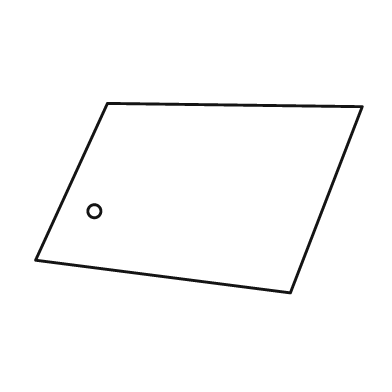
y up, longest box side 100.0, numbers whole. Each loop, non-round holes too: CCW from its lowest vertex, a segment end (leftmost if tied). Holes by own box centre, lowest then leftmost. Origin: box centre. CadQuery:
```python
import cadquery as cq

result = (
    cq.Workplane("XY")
    .moveTo(28.0, -29.0)
    .lineTo(50.0, 28.0)
    .lineTo(-28.0, 29.0)
    .lineTo(-50.0, -19.0)
    .close()
    .moveTo(-32.0, -4.0)
    .circle(2.0)
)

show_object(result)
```